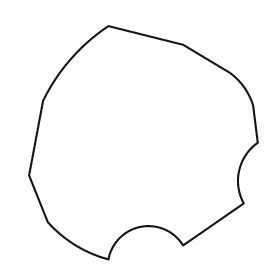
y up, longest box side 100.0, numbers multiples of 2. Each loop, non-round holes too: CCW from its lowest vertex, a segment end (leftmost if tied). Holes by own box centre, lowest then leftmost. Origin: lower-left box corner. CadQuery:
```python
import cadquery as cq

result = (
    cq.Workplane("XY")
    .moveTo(34.0, 0.0)
    .threePointArc((48.0, 14.0), (66.0, 6.0))
    .lineTo(92.0, 24.0)
    .threePointArc((90.0, 38.0), (98.0, 50.0))
    .lineTo(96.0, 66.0)
    .threePointArc((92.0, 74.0), (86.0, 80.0))
    .lineTo(66.0, 92.0)
    .lineTo(34.0, 100.0)
    .threePointArc((18.0, 86.0), (6.0, 68.0))
    .lineTo(0.0, 36.0)
    .lineTo(8.0, 16.0)
    .threePointArc((20.0, 6.0), (34.0, 0.0))
    .close()
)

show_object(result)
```